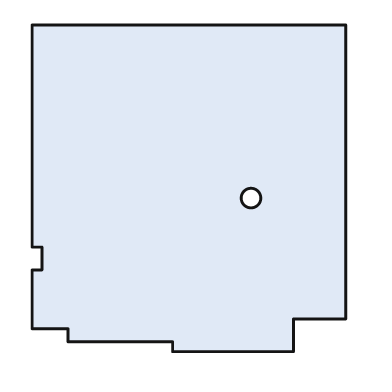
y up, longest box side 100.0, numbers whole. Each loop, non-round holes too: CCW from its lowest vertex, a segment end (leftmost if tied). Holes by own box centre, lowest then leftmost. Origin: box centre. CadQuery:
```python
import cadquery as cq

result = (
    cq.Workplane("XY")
    .moveTo(-5.0, -50.0)
    .lineTo(32.0, -50.0)
    .lineTo(32.0, -40.0)
    .lineTo(48.0, -40.0)
    .lineTo(48.0, 50.0)
    .lineTo(-48.0, 50.0)
    .lineTo(-48.0, -18.0)
    .lineTo(-45.0, -18.0)
    .lineTo(-45.0, -25.0)
    .lineTo(-48.0, -25.0)
    .lineTo(-48.0, -43.0)
    .lineTo(-37.0, -43.0)
    .lineTo(-37.0, -47.0)
    .lineTo(-5.0, -47.0)
    .close()
    .moveTo(19.0, -3.0)
    .circle(3.0)
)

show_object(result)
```